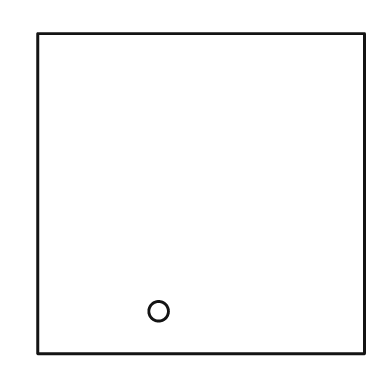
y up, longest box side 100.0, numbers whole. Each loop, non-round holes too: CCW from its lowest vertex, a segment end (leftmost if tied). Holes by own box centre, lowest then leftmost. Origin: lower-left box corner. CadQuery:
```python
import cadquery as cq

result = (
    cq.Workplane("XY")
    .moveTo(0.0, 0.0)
    .lineTo(100.0, 0.0)
    .lineTo(100.0, 98.0)
    .lineTo(0.0, 98.0)
    .close()
    .moveTo(37.0, 13.0)
    .circle(3.0)
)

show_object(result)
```